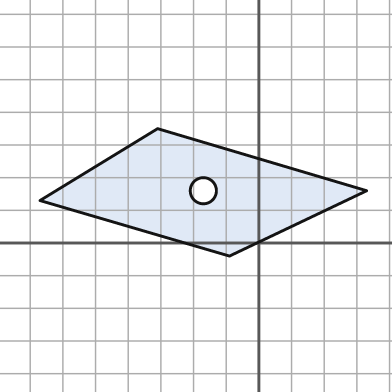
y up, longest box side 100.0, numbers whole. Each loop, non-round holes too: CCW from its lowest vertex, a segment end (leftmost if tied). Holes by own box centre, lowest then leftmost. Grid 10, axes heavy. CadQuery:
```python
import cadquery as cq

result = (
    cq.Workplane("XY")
    .moveTo(-9.0, -4.0)
    .lineTo(33.0, 16.0)
    .lineTo(-31.0, 35.0)
    .lineTo(-67.0, 13.0)
    .close()
    .moveTo(-17.0, 16.0)
    .circle(4.0)
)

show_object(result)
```